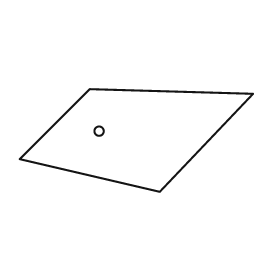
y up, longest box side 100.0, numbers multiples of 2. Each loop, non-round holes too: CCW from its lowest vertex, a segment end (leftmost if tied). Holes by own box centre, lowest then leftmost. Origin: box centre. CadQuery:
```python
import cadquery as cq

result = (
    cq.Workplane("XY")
    .moveTo(10.0, -22.0)
    .lineTo(50.0, 20.0)
    .lineTo(-20.0, 22.0)
    .lineTo(-50.0, -8.0)
    .close()
    .moveTo(-16.0, 4.0)
    .circle(2.0)
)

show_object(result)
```